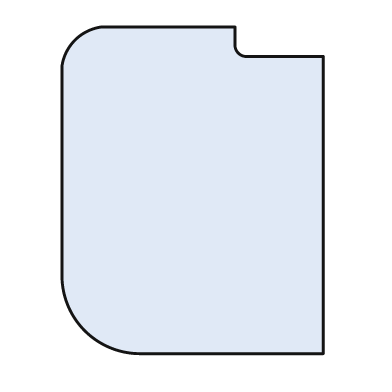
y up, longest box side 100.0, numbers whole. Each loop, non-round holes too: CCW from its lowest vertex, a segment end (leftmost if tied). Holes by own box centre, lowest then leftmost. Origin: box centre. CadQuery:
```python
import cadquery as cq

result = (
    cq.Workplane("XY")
    .moveTo(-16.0, -50.0)
    .lineTo(40.0, -50.0)
    .lineTo(40.0, 41.0)
    .lineTo(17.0, 41.0)
    .threePointArc((14.0, 42.0), (13.0, 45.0))
    .lineTo(13.0, 50.0)
    .lineTo(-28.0, 50.0)
    .threePointArc((-36.0, 46.0), (-40.0, 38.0))
    .lineTo(-40.0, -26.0)
    .threePointArc((-33.0, -43.0), (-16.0, -50.0))
    .close()
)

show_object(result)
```